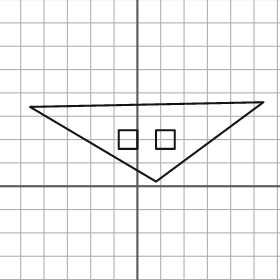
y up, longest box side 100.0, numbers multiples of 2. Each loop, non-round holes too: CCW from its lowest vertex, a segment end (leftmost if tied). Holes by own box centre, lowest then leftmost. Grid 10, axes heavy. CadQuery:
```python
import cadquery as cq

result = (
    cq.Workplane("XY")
    .moveTo(8.0, 2.0)
    .lineTo(54.0, 36.0)
    .lineTo(-46.0, 34.0)
    .close()
    .moveTo(-8.0, 16.0)
    .lineTo(0.0, 16.0)
    .lineTo(0.0, 24.0)
    .lineTo(-8.0, 24.0)
    .close()
    .moveTo(8.0, 16.0)
    .lineTo(16.0, 16.0)
    .lineTo(16.0, 24.0)
    .lineTo(8.0, 24.0)
    .close()
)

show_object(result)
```